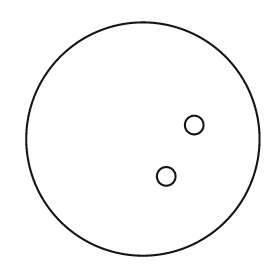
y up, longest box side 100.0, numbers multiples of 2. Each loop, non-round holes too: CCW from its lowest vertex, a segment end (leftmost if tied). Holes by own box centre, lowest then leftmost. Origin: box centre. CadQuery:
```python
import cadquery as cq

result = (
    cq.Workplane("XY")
    .moveTo(0.0, 0.0)
    .circle(50.0)
    .moveTo(10.0, -16.0)
    .circle(4.0)
    .moveTo(22.0, 6.0)
    .circle(4.0)
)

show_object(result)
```